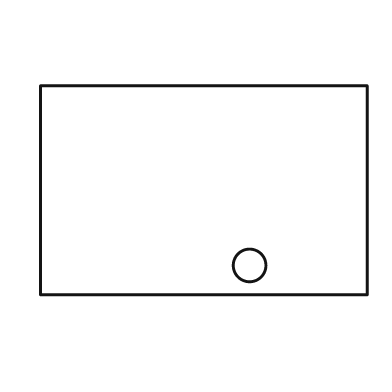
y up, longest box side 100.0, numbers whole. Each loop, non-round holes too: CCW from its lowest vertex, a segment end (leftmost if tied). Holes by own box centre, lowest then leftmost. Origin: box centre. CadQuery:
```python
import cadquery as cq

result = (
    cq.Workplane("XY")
    .moveTo(-50.0, -32.0)
    .lineTo(50.0, -32.0)
    .lineTo(50.0, 32.0)
    .lineTo(-50.0, 32.0)
    .close()
    .moveTo(14.0, -23.0)
    .circle(5.0)
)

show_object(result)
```